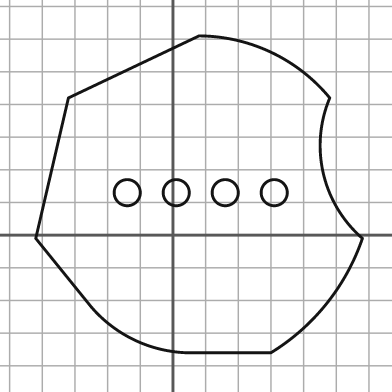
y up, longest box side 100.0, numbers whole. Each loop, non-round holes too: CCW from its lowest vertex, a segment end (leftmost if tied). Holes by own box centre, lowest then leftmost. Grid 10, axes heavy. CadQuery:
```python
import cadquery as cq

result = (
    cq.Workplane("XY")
    .moveTo(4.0, -36.0)
    .lineTo(30.0, -36.0)
    .threePointArc((47.0, -21.0), (58.0, -1.0))
    .threePointArc((46.0, 19.0), (48.0, 42.0))
    .threePointArc((30.0, 56.0), (8.0, 61.0))
    .lineTo(-32.0, 42.0)
    .lineTo(-42.0, -1.0)
    .lineTo(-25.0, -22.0)
    .threePointArc((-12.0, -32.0), (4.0, -36.0))
    .close()
    .moveTo(-14.0, 13.0)
    .circle(4.0)
    .moveTo(1.0, 13.0)
    .circle(4.0)
    .moveTo(16.0, 13.0)
    .circle(4.0)
    .moveTo(31.0, 13.0)
    .circle(4.0)
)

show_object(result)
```